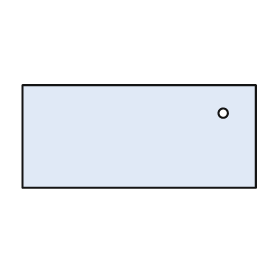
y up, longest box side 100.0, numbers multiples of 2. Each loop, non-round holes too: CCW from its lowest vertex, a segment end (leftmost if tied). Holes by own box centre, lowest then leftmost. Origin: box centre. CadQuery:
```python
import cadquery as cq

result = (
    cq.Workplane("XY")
    .moveTo(-50.0, -22.0)
    .lineTo(50.0, -22.0)
    .lineTo(50.0, 22.0)
    .lineTo(-50.0, 22.0)
    .close()
    .moveTo(36.0, 10.0)
    .circle(2.0)
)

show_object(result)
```